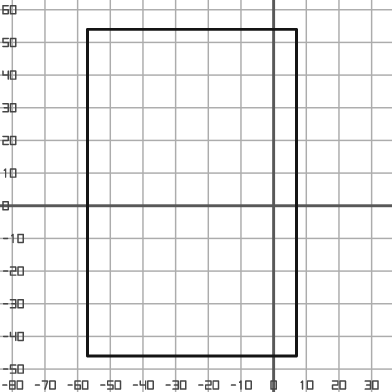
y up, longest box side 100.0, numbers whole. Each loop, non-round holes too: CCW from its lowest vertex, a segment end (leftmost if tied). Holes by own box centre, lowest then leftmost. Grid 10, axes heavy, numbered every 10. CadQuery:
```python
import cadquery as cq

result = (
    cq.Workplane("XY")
    .moveTo(-57.0, -46.0)
    .lineTo(7.0, -46.0)
    .lineTo(7.0, 54.0)
    .lineTo(-57.0, 54.0)
    .close()
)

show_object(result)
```